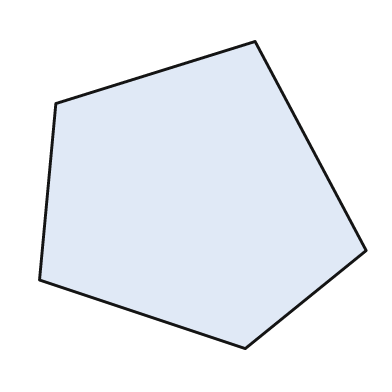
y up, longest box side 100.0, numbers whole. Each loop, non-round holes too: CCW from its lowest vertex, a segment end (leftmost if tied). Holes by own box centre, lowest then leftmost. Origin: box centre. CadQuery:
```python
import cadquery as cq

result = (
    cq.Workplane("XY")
    .moveTo(13.0, -47.0)
    .lineTo(50.0, -17.0)
    .lineTo(16.0, 47.0)
    .lineTo(-45.0, 28.0)
    .lineTo(-50.0, -26.0)
    .close()
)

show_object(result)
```